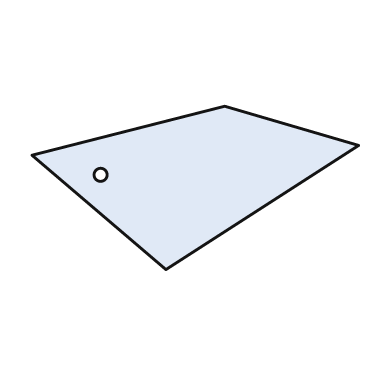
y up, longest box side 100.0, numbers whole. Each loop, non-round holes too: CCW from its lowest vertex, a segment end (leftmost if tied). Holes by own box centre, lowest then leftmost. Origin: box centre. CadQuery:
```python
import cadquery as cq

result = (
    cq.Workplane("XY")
    .moveTo(-9.0, -25.0)
    .lineTo(50.0, 13.0)
    .lineTo(9.0, 25.0)
    .lineTo(-50.0, 10.0)
    .close()
    .moveTo(-29.0, 4.0)
    .circle(2.0)
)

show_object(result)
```